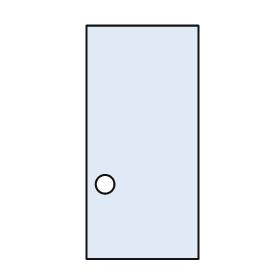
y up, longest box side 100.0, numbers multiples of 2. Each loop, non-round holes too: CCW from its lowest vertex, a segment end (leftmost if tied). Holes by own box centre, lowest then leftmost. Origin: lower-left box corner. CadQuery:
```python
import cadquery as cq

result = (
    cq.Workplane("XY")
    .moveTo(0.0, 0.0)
    .lineTo(48.0, 0.0)
    .lineTo(48.0, 100.0)
    .lineTo(0.0, 100.0)
    .close()
    .moveTo(8.0, 32.0)
    .circle(4.0)
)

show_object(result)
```